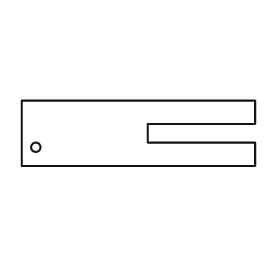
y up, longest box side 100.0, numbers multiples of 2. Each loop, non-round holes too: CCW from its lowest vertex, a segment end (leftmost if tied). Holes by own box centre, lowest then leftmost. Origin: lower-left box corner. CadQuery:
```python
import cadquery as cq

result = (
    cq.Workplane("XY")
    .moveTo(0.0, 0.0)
    .lineTo(100.0, 0.0)
    .lineTo(100.0, 10.0)
    .lineTo(54.0, 10.0)
    .lineTo(54.0, 18.0)
    .lineTo(100.0, 18.0)
    .lineTo(100.0, 28.0)
    .lineTo(0.0, 28.0)
    .close()
    .moveTo(6.0, 8.0)
    .circle(2.0)
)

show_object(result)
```